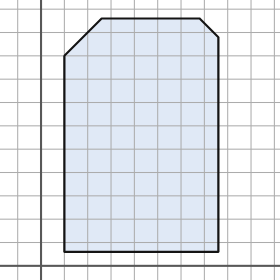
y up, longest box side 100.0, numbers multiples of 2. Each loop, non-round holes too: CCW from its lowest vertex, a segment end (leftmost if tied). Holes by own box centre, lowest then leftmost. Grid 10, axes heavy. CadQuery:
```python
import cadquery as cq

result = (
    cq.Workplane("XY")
    .moveTo(10.0, 6.0)
    .lineTo(76.0, 6.0)
    .lineTo(76.0, 98.0)
    .lineTo(68.0, 106.0)
    .lineTo(26.0, 106.0)
    .lineTo(10.0, 90.0)
    .close()
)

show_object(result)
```